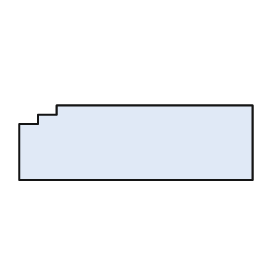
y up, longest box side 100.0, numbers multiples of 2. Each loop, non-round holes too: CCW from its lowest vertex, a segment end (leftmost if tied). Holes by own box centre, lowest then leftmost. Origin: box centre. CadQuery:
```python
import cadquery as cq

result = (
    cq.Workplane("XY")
    .moveTo(-50.0, -16.0)
    .lineTo(50.0, -16.0)
    .lineTo(50.0, 16.0)
    .lineTo(-34.0, 16.0)
    .lineTo(-34.0, 12.0)
    .lineTo(-42.0, 12.0)
    .lineTo(-42.0, 8.0)
    .lineTo(-50.0, 8.0)
    .close()
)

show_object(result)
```